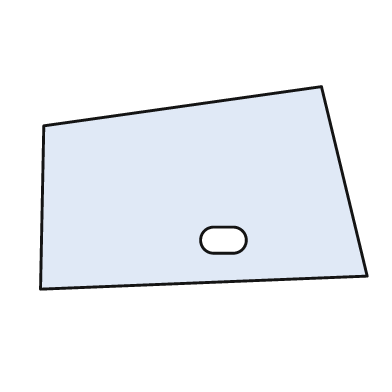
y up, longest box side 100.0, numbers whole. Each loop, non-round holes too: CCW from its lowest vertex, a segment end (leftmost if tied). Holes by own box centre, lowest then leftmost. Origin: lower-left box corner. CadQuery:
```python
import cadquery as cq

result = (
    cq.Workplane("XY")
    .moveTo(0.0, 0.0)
    .lineTo(100.0, 4.0)
    .lineTo(86.0, 62.0)
    .lineTo(1.0, 50.0)
    .close()
    .moveTo(53.0, 11.0)
    .lineTo(59.0, 11.0)
    .threePointArc((63.0, 15.0), (59.0, 19.0))
    .lineTo(53.0, 19.0)
    .threePointArc((49.0, 15.0), (53.0, 11.0))
    .close()
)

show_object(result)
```